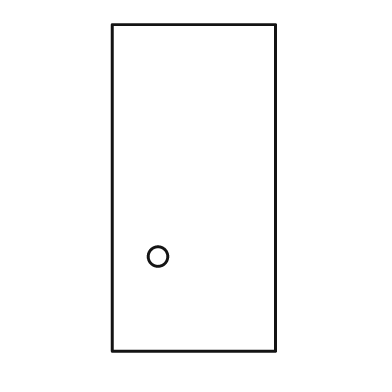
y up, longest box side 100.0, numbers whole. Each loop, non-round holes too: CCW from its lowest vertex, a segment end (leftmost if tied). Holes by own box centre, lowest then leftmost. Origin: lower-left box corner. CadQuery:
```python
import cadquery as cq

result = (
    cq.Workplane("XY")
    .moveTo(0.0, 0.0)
    .lineTo(50.0, 0.0)
    .lineTo(50.0, 100.0)
    .lineTo(0.0, 100.0)
    .close()
    .moveTo(14.0, 29.0)
    .circle(3.0)
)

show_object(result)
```